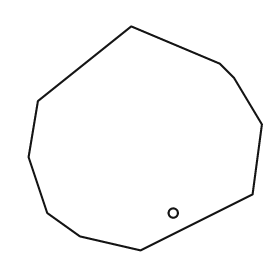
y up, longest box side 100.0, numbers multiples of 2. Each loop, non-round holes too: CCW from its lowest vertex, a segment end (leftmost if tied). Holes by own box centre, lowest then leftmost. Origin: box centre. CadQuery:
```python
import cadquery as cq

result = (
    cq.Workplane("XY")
    .moveTo(-2.0, -48.0)
    .lineTo(46.0, -24.0)
    .lineTo(50.0, 6.0)
    .lineTo(38.0, 26.0)
    .lineTo(32.0, 32.0)
    .lineTo(-6.0, 48.0)
    .lineTo(-46.0, 16.0)
    .lineTo(-50.0, -8.0)
    .lineTo(-42.0, -32.0)
    .lineTo(-28.0, -42.0)
    .close()
    .moveTo(12.0, -32.0)
    .circle(2.0)
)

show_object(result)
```